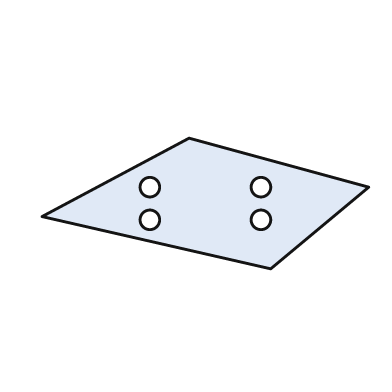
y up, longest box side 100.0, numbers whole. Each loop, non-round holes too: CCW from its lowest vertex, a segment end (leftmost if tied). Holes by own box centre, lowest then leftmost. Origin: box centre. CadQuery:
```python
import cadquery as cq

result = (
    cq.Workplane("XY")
    .moveTo(20.0, -20.0)
    .lineTo(50.0, 5.0)
    .lineTo(-5.0, 20.0)
    .lineTo(-50.0, -4.0)
    .close()
    .moveTo(-17.0, -5.0)
    .circle(3.0)
    .moveTo(17.0, -5.0)
    .circle(3.0)
    .moveTo(-17.0, 5.0)
    .circle(3.0)
    .moveTo(17.0, 5.0)
    .circle(3.0)
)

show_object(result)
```